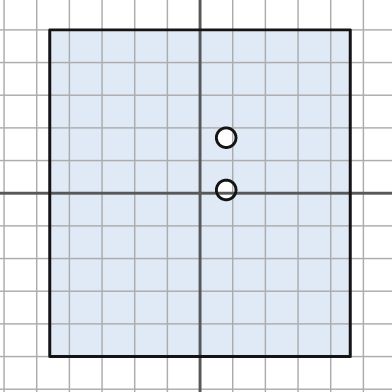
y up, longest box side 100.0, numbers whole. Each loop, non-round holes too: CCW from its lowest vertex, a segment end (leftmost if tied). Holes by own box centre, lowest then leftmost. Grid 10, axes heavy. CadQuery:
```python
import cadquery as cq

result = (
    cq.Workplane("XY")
    .moveTo(-46.0, -50.0)
    .lineTo(46.0, -50.0)
    .lineTo(46.0, 50.0)
    .lineTo(-46.0, 50.0)
    .close()
    .moveTo(8.0, 1.0)
    .circle(3.0)
    .moveTo(8.0, 17.0)
    .circle(3.0)
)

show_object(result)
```